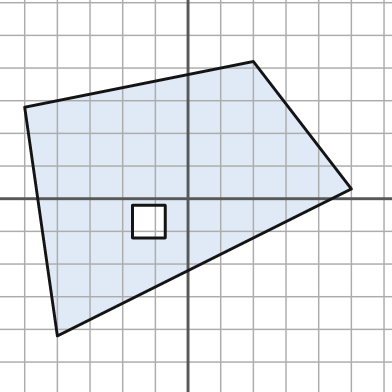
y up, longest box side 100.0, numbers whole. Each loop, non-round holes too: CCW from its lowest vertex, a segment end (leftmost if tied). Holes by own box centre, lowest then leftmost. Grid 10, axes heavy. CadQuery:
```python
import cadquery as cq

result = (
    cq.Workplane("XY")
    .moveTo(-40.0, -42.0)
    .lineTo(50.0, 3.0)
    .lineTo(20.0, 42.0)
    .lineTo(-50.0, 28.0)
    .close()
    .moveTo(-17.0, -12.0)
    .lineTo(-7.0, -12.0)
    .lineTo(-7.0, -2.0)
    .lineTo(-17.0, -2.0)
    .close()
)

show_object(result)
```